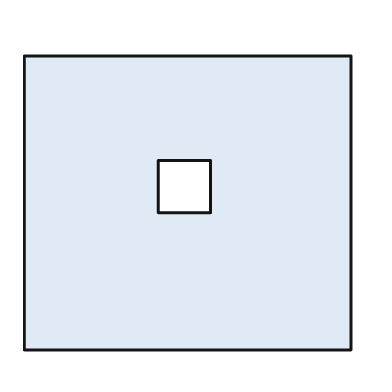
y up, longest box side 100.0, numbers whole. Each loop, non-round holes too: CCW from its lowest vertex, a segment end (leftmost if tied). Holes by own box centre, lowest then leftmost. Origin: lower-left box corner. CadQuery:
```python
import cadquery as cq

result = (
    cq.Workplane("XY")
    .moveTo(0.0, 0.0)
    .lineTo(100.0, 0.0)
    .lineTo(100.0, 90.0)
    .lineTo(0.0, 90.0)
    .close()
    .moveTo(41.0, 42.0)
    .lineTo(57.0, 42.0)
    .lineTo(57.0, 58.0)
    .lineTo(41.0, 58.0)
    .close()
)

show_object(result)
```